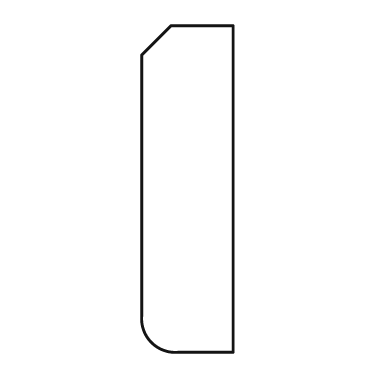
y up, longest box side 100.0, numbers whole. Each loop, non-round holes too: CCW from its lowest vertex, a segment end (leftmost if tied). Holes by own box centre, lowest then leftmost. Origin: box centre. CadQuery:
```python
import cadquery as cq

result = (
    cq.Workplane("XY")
    .moveTo(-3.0, -50.0)
    .lineTo(14.0, -50.0)
    .lineTo(14.0, 50.0)
    .lineTo(-5.0, 50.0)
    .lineTo(-14.0, 41.0)
    .lineTo(-14.0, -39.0)
    .threePointArc((-11.0, -47.0), (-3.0, -50.0))
    .close()
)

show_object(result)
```